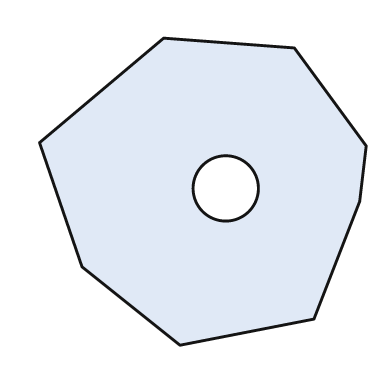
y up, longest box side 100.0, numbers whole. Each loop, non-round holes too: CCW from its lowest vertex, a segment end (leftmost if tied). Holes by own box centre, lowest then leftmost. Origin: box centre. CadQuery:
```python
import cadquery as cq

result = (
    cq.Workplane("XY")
    .moveTo(-7.0, -47.0)
    .lineTo(34.0, -39.0)
    .lineTo(48.0, -3.0)
    .lineTo(50.0, 14.0)
    .lineTo(28.0, 44.0)
    .lineTo(-12.0, 47.0)
    .lineTo(-50.0, 15.0)
    .lineTo(-37.0, -23.0)
    .close()
    .moveTo(7.0, 1.0)
    .circle(10.0)
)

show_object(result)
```